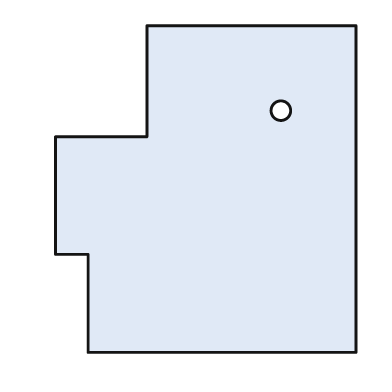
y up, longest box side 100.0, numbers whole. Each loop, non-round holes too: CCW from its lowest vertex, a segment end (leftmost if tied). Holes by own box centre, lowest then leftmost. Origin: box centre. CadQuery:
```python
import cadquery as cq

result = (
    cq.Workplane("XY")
    .moveTo(-36.0, -50.0)
    .lineTo(46.0, -50.0)
    .lineTo(46.0, 50.0)
    .lineTo(-18.0, 50.0)
    .lineTo(-18.0, 16.0)
    .lineTo(-46.0, 16.0)
    .lineTo(-46.0, -20.0)
    .lineTo(-36.0, -20.0)
    .close()
    .moveTo(23.0, 24.0)
    .circle(3.0)
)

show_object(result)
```